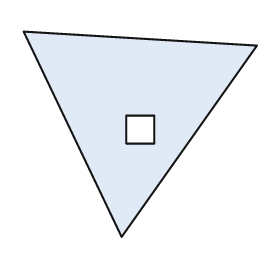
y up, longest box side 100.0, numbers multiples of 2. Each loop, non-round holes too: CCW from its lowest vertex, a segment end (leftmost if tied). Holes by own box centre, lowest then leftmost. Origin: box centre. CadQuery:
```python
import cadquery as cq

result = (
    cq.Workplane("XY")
    .moveTo(-8.0, -44.0)
    .lineTo(50.0, 38.0)
    .lineTo(-50.0, 44.0)
    .close()
    .moveTo(-6.0, -4.0)
    .lineTo(6.0, -4.0)
    .lineTo(6.0, 8.0)
    .lineTo(-6.0, 8.0)
    .close()
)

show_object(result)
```